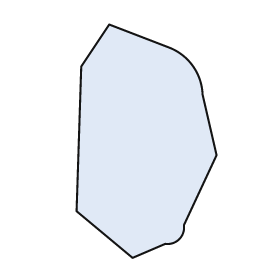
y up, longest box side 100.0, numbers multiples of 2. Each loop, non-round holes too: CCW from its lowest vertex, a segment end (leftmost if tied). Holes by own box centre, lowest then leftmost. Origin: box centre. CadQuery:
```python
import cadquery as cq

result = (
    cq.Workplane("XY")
    .moveTo(-6.0, -50.0)
    .lineTo(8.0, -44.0)
    .threePointArc((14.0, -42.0), (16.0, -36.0))
    .lineTo(30.0, -6.0)
    .lineTo(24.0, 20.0)
    .threePointArc((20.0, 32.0), (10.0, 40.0))
    .lineTo(-16.0, 50.0)
    .lineTo(-28.0, 32.0)
    .lineTo(-30.0, -30.0)
    .close()
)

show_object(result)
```